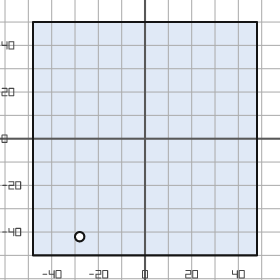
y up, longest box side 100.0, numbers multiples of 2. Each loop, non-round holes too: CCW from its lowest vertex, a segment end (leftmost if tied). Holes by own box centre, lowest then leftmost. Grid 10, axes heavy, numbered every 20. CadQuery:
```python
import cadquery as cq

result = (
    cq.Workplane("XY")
    .moveTo(-48.0, -50.0)
    .lineTo(48.0, -50.0)
    .lineTo(48.0, 50.0)
    .lineTo(-48.0, 50.0)
    .close()
    .moveTo(-28.0, -42.0)
    .circle(2.0)
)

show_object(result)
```